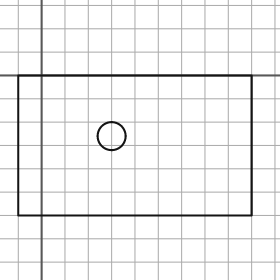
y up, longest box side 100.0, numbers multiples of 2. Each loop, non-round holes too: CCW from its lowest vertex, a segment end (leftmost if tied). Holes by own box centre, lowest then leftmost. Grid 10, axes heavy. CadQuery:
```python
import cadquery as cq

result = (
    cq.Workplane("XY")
    .moveTo(-10.0, -60.0)
    .lineTo(90.0, -60.0)
    .lineTo(90.0, 0.0)
    .lineTo(-10.0, 0.0)
    .close()
    .moveTo(30.0, -26.0)
    .circle(6.0)
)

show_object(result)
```